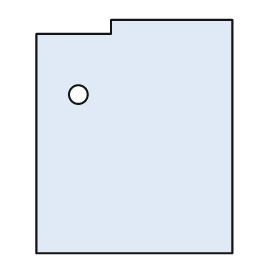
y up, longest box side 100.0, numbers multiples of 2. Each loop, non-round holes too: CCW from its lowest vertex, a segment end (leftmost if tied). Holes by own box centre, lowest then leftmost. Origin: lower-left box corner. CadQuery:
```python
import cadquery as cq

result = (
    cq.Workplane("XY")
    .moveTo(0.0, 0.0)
    .lineTo(84.0, 0.0)
    .lineTo(84.0, 100.0)
    .lineTo(32.0, 100.0)
    .lineTo(32.0, 94.0)
    .lineTo(0.0, 94.0)
    .close()
    .moveTo(18.0, 68.0)
    .circle(4.0)
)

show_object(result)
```